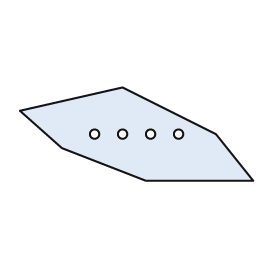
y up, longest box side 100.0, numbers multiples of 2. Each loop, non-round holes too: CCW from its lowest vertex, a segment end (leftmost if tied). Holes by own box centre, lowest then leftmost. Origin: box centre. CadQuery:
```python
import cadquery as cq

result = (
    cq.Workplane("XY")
    .moveTo(4.0, -20.0)
    .lineTo(50.0, -20.0)
    .lineTo(34.0, 0.0)
    .lineTo(-6.0, 20.0)
    .lineTo(-50.0, 10.0)
    .lineTo(-32.0, -6.0)
    .close()
    .moveTo(-18.0, 0.0)
    .circle(2.0)
    .moveTo(-6.0, 0.0)
    .circle(2.0)
    .moveTo(6.0, 0.0)
    .circle(2.0)
    .moveTo(18.0, 0.0)
    .circle(2.0)
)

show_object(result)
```